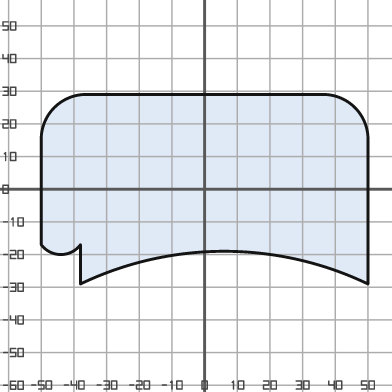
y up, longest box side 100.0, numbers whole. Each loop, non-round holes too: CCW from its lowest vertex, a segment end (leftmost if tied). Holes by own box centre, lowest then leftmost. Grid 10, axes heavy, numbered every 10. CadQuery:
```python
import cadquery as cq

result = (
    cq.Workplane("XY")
    .moveTo(-38.0, -29.0)
    .threePointArc((6.0, -19.0), (50.0, -29.0))
    .lineTo(50.0, 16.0)
    .threePointArc((46.0, 25.0), (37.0, 29.0))
    .lineTo(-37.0, 29.0)
    .threePointArc((-46.0, 25.0), (-50.0, 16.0))
    .lineTo(-50.0, -17.0)
    .threePointArc((-44.0, -20.0), (-38.0, -17.0))
    .close()
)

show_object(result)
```